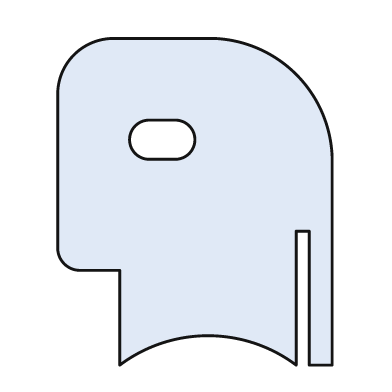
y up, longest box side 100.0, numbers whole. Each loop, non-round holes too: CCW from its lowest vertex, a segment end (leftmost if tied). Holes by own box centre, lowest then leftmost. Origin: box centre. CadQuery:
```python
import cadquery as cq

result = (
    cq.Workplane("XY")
    .moveTo(-23.0, -50.0)
    .threePointArc((4.0, -41.0), (31.0, -50.0))
    .lineTo(31.0, -9.0)
    .lineTo(35.0, -9.0)
    .lineTo(35.0, -50.0)
    .lineTo(42.0, -50.0)
    .lineTo(42.0, 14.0)
    .threePointArc((31.0, 39.0), (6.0, 50.0))
    .lineTo(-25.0, 50.0)
    .threePointArc((-37.0, 45.0), (-42.0, 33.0))
    .lineTo(-42.0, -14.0)
    .threePointArc((-40.0, -19.0), (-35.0, -21.0))
    .lineTo(-23.0, -21.0)
    .close()
    .moveTo(-14.0, 13.0)
    .lineTo(-6.0, 13.0)
    .threePointArc((0.0, 19.0), (-6.0, 25.0))
    .lineTo(-14.0, 25.0)
    .threePointArc((-20.0, 19.0), (-14.0, 13.0))
    .close()
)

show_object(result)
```